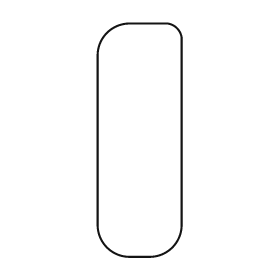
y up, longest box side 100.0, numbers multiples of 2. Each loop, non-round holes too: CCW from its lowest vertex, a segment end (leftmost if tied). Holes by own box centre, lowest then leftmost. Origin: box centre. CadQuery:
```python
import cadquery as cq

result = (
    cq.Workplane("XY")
    .moveTo(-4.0, -50.0)
    .lineTo(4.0, -50.0)
    .threePointArc((14.0, -46.0), (18.0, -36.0))
    .lineTo(18.0, 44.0)
    .threePointArc((16.0, 48.0), (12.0, 50.0))
    .lineTo(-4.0, 50.0)
    .threePointArc((-14.0, 46.0), (-18.0, 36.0))
    .lineTo(-18.0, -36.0)
    .threePointArc((-14.0, -46.0), (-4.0, -50.0))
    .close()
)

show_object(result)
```